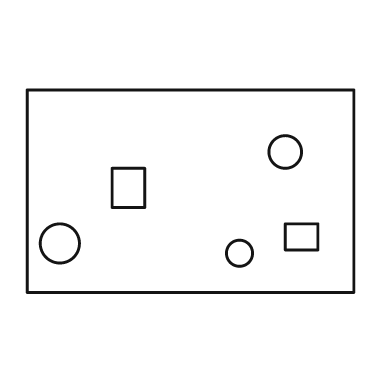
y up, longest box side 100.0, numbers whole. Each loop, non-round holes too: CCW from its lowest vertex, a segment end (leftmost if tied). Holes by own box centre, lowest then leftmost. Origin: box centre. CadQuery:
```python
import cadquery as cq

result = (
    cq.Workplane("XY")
    .moveTo(-50.0, -31.0)
    .lineTo(50.0, -31.0)
    .lineTo(50.0, 31.0)
    .lineTo(-50.0, 31.0)
    .close()
    .moveTo(15.0, -19.0)
    .circle(4.0)
    .moveTo(-40.0, -16.0)
    .circle(6.0)
    .moveTo(29.0, -18.0)
    .lineTo(39.0, -18.0)
    .lineTo(39.0, -10.0)
    .lineTo(29.0, -10.0)
    .close()
    .moveTo(-24.0, -5.0)
    .lineTo(-14.0, -5.0)
    .lineTo(-14.0, 7.0)
    .lineTo(-24.0, 7.0)
    .close()
    .moveTo(29.0, 12.0)
    .circle(5.0)
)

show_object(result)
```